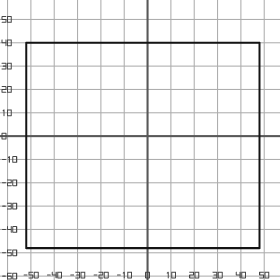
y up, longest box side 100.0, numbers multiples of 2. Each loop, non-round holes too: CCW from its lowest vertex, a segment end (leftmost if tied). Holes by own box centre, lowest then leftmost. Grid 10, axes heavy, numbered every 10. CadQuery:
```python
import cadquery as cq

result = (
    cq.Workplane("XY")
    .moveTo(-52.0, -48.0)
    .lineTo(48.0, -48.0)
    .lineTo(48.0, 40.0)
    .lineTo(-52.0, 40.0)
    .close()
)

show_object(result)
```